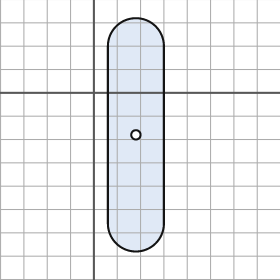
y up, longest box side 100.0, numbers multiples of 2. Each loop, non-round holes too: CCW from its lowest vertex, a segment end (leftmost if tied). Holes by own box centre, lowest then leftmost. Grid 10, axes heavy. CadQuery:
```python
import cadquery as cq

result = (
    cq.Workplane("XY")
    .moveTo(6.0, -56.0)
    .threePointArc((18.0, -68.0), (30.0, -56.0))
    .lineTo(30.0, 20.0)
    .threePointArc((18.0, 32.0), (6.0, 20.0))
    .close()
    .moveTo(18.0, -18.0)
    .circle(2.0)
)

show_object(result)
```